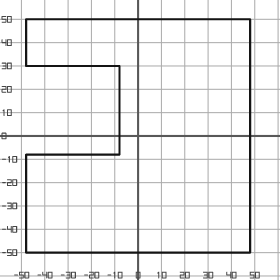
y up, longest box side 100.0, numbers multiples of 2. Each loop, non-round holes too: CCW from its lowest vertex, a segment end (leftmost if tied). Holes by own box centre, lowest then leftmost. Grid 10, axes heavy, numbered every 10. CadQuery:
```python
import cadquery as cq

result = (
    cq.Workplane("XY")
    .moveTo(-48.0, -50.0)
    .lineTo(48.0, -50.0)
    .lineTo(48.0, 50.0)
    .lineTo(-48.0, 50.0)
    .lineTo(-48.0, 30.0)
    .lineTo(-8.0, 30.0)
    .lineTo(-8.0, -8.0)
    .lineTo(-48.0, -8.0)
    .close()
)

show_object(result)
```